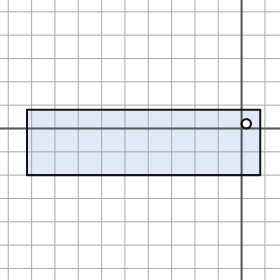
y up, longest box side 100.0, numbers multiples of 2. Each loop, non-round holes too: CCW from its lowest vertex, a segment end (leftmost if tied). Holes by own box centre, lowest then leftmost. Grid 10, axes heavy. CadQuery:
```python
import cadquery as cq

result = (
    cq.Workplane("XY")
    .moveTo(-92.0, -20.0)
    .lineTo(8.0, -20.0)
    .lineTo(8.0, 8.0)
    .lineTo(-92.0, 8.0)
    .close()
    .moveTo(2.0, 2.0)
    .circle(2.0)
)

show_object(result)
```